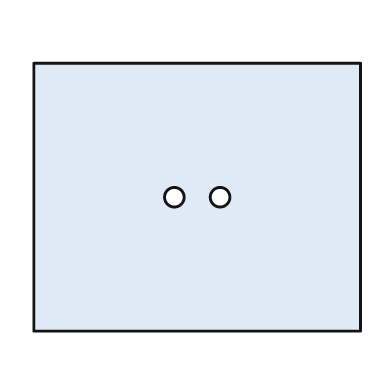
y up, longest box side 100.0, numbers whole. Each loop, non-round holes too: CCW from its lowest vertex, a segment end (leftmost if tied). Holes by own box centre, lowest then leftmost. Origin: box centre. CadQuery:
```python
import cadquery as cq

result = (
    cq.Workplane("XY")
    .moveTo(-50.0, -41.0)
    .lineTo(50.0, -41.0)
    .lineTo(50.0, 41.0)
    .lineTo(-50.0, 41.0)
    .close()
    .moveTo(-7.0, 0.0)
    .circle(3.0)
    .moveTo(7.0, 0.0)
    .circle(3.0)
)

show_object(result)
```